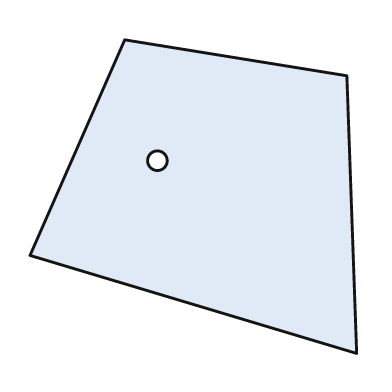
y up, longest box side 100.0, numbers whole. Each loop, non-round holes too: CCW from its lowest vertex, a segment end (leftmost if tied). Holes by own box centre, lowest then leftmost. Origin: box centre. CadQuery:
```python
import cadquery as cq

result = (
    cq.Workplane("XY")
    .moveTo(50.0, -48.0)
    .lineTo(47.0, 37.0)
    .lineTo(-21.0, 48.0)
    .lineTo(-50.0, -18.0)
    .close()
    .moveTo(-11.0, 11.0)
    .circle(3.0)
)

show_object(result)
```